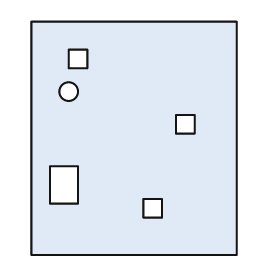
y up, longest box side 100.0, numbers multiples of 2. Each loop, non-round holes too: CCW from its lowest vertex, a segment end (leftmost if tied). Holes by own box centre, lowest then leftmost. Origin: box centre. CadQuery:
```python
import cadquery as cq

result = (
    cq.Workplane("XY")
    .moveTo(-44.0, -50.0)
    .lineTo(44.0, -50.0)
    .lineTo(44.0, 50.0)
    .lineTo(-44.0, 50.0)
    .close()
    .moveTo(4.0, -34.0)
    .lineTo(12.0, -34.0)
    .lineTo(12.0, -26.0)
    .lineTo(4.0, -26.0)
    .close()
    .moveTo(-36.0, -28.0)
    .lineTo(-24.0, -28.0)
    .lineTo(-24.0, -12.0)
    .lineTo(-36.0, -12.0)
    .close()
    .moveTo(18.0, 2.0)
    .lineTo(26.0, 2.0)
    .lineTo(26.0, 10.0)
    .lineTo(18.0, 10.0)
    .close()
    .moveTo(-28.0, 20.0)
    .circle(4.0)
    .moveTo(-28.0, 30.0)
    .lineTo(-20.0, 30.0)
    .lineTo(-20.0, 38.0)
    .lineTo(-28.0, 38.0)
    .close()
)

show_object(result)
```